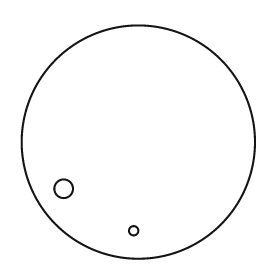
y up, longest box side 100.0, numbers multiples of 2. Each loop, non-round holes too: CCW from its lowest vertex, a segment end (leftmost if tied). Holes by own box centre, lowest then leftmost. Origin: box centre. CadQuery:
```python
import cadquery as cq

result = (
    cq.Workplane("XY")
    .moveTo(0.0, 0.0)
    .circle(50.0)
    .moveTo(-2.0, -38.0)
    .circle(2.0)
    .moveTo(-32.0, -20.0)
    .circle(4.0)
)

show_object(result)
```